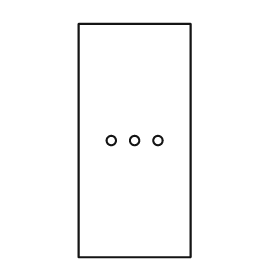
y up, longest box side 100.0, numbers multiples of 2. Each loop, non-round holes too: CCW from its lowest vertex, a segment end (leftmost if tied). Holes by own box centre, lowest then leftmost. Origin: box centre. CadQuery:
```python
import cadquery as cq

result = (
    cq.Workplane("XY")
    .moveTo(-24.0, -50.0)
    .lineTo(24.0, -50.0)
    .lineTo(24.0, 50.0)
    .lineTo(-24.0, 50.0)
    .close()
    .moveTo(-10.0, 0.0)
    .circle(2.0)
    .moveTo(0.0, 0.0)
    .circle(2.0)
    .moveTo(10.0, 0.0)
    .circle(2.0)
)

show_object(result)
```